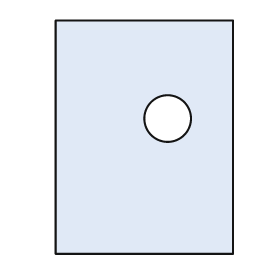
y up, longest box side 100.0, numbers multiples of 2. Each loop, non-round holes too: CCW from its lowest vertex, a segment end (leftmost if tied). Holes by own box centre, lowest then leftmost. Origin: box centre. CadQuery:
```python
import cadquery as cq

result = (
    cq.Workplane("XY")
    .moveTo(-38.0, -50.0)
    .lineTo(38.0, -50.0)
    .lineTo(38.0, 50.0)
    .lineTo(-38.0, 50.0)
    .close()
    .moveTo(10.0, 8.0)
    .circle(10.0)
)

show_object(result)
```